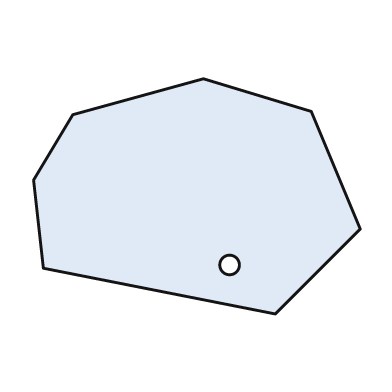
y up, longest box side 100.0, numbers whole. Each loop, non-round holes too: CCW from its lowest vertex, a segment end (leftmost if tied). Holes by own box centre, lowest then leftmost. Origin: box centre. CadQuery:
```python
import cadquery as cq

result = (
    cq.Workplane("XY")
    .moveTo(24.0, -36.0)
    .lineTo(50.0, -10.0)
    .lineTo(35.0, 26.0)
    .lineTo(2.0, 36.0)
    .lineTo(-38.0, 25.0)
    .lineTo(-50.0, 5.0)
    .lineTo(-47.0, -22.0)
    .close()
    .moveTo(10.0, -21.0)
    .circle(3.0)
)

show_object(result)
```